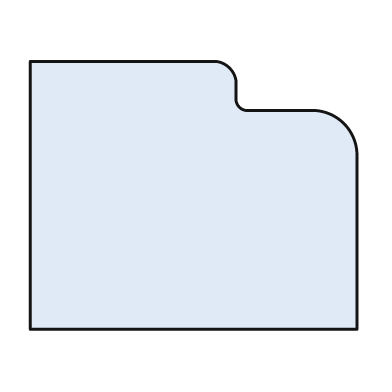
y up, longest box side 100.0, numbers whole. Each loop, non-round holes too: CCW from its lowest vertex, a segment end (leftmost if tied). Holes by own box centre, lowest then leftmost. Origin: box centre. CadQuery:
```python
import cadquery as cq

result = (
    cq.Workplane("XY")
    .moveTo(-50.0, -41.0)
    .lineTo(50.0, -41.0)
    .lineTo(50.0, 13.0)
    .threePointArc((46.0, 22.0), (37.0, 26.0))
    .lineTo(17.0, 26.0)
    .threePointArc((14.0, 27.0), (13.0, 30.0))
    .lineTo(13.0, 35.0)
    .threePointArc((11.0, 39.0), (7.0, 41.0))
    .lineTo(-50.0, 41.0)
    .close()
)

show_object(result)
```